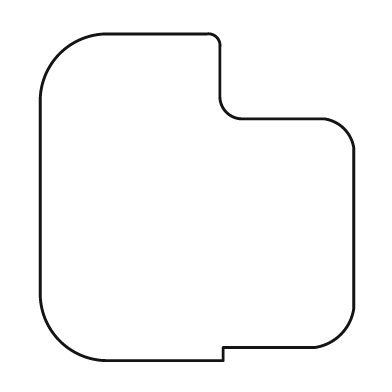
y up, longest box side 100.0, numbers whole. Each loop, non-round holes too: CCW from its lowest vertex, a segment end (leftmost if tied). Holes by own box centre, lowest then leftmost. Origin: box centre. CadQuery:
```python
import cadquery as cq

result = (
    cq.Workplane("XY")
    .moveTo(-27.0, -50.0)
    .lineTo(8.0, -50.0)
    .lineTo(8.0, -46.0)
    .lineTo(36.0, -46.0)
    .threePointArc((44.0, -42.0), (48.0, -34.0))
    .lineTo(48.0, 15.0)
    .threePointArc((45.0, 21.0), (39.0, 24.0))
    .lineTo(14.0, 24.0)
    .threePointArc((9.0, 26.0), (7.0, 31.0))
    .lineTo(7.0, 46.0)
    .threePointArc((6.0, 49.0), (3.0, 50.0))
    .lineTo(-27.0, 50.0)
    .threePointArc((-42.0, 44.0), (-48.0, 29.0))
    .lineTo(-48.0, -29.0)
    .threePointArc((-42.0, -44.0), (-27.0, -50.0))
    .close()
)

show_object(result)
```